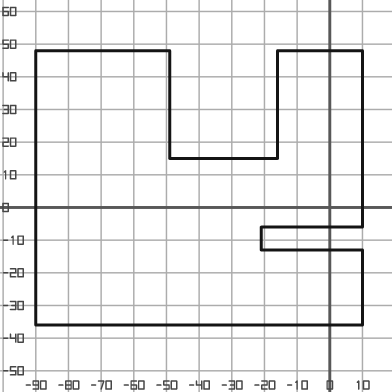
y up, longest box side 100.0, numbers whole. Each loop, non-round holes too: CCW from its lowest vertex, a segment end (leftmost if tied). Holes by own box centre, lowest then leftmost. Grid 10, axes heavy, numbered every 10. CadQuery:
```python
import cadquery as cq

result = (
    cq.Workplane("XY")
    .moveTo(-90.0, -36.0)
    .lineTo(10.0, -36.0)
    .lineTo(10.0, -13.0)
    .lineTo(-21.0, -13.0)
    .lineTo(-21.0, -6.0)
    .lineTo(10.0, -6.0)
    .lineTo(10.0, 48.0)
    .lineTo(-16.0, 48.0)
    .lineTo(-16.0, 15.0)
    .lineTo(-49.0, 15.0)
    .lineTo(-49.0, 48.0)
    .lineTo(-90.0, 48.0)
    .close()
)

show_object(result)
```